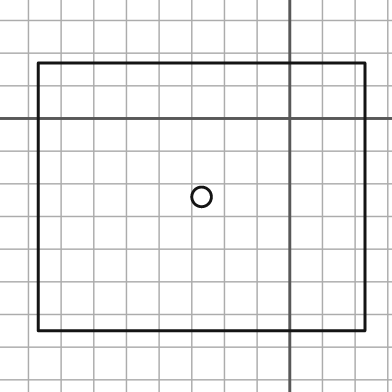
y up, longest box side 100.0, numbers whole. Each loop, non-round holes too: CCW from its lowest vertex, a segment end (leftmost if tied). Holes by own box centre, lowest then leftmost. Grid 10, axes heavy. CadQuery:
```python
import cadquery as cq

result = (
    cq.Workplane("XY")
    .moveTo(-77.0, -65.0)
    .lineTo(23.0, -65.0)
    .lineTo(23.0, 17.0)
    .lineTo(-77.0, 17.0)
    .close()
    .moveTo(-27.0, -24.0)
    .circle(3.0)
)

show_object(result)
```